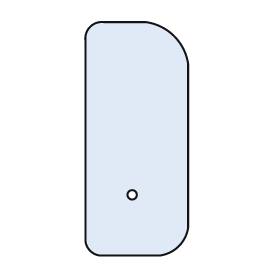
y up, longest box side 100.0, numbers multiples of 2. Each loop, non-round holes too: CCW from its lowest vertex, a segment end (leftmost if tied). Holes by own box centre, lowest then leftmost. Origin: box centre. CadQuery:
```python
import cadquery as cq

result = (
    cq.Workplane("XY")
    .moveTo(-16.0, -50.0)
    .lineTo(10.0, -50.0)
    .threePointArc((18.0, -46.0), (22.0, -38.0))
    .lineTo(22.0, 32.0)
    .threePointArc((16.0, 44.0), (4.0, 50.0))
    .lineTo(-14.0, 50.0)
    .threePointArc((-20.0, 48.0), (-22.0, 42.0))
    .lineTo(-22.0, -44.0)
    .threePointArc((-20.0, -48.0), (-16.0, -50.0))
    .close()
    .moveTo(-2.0, -24.0)
    .circle(2.0)
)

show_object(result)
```